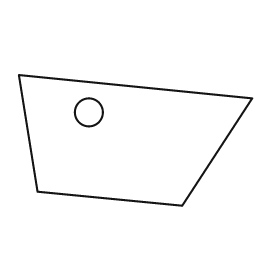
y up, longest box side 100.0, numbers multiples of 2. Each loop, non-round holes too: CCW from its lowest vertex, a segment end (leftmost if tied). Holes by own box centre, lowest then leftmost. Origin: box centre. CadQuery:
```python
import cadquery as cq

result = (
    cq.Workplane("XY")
    .moveTo(20.0, -28.0)
    .lineTo(50.0, 18.0)
    .lineTo(-50.0, 28.0)
    .lineTo(-42.0, -22.0)
    .close()
    .moveTo(-20.0, 12.0)
    .circle(6.0)
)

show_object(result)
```